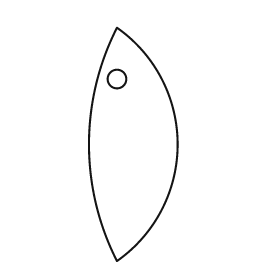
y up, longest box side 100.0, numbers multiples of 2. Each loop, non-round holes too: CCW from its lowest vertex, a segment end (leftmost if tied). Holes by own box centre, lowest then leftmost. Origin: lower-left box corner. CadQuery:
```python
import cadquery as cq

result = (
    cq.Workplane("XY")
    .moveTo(12.0, 0.0)
    .threePointArc((38.0, 50.0), (12.0, 100.0))
    .threePointArc((0.0, 50.0), (12.0, 0.0))
    .close()
    .moveTo(12.0, 78.0)
    .circle(4.0)
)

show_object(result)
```